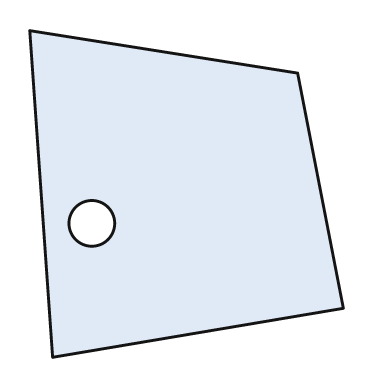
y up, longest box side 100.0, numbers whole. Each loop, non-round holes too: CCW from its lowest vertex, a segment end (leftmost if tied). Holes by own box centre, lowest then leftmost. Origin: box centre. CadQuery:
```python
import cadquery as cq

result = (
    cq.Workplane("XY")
    .moveTo(-41.0, -50.0)
    .lineTo(48.0, -35.0)
    .lineTo(34.0, 37.0)
    .lineTo(-48.0, 50.0)
    .close()
    .moveTo(-29.0, -9.0)
    .circle(7.0)
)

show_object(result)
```